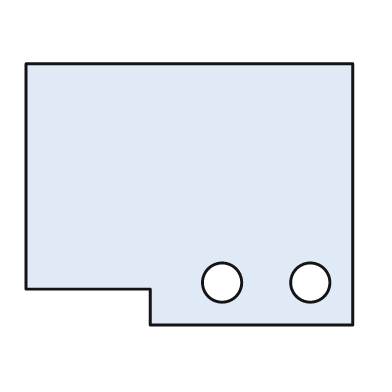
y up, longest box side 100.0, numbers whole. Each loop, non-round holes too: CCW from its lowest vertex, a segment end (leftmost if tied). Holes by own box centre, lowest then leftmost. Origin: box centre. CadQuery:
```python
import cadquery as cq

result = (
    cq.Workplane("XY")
    .moveTo(-12.0, -40.0)
    .lineTo(50.0, -40.0)
    .lineTo(50.0, 40.0)
    .lineTo(-50.0, 40.0)
    .lineTo(-50.0, -29.0)
    .lineTo(-12.0, -29.0)
    .close()
    .moveTo(10.0, -27.0)
    .circle(6.0)
    .moveTo(37.0, -27.0)
    .circle(6.0)
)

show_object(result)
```